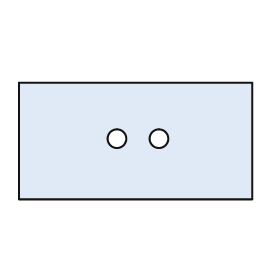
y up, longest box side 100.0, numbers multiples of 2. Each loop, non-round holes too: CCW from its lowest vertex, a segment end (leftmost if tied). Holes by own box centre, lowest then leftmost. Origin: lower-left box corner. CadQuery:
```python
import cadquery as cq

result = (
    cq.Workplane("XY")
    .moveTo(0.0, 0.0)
    .lineTo(100.0, 0.0)
    .lineTo(100.0, 50.0)
    .lineTo(0.0, 50.0)
    .close()
    .moveTo(42.0, 26.0)
    .circle(4.0)
    .moveTo(60.0, 26.0)
    .circle(4.0)
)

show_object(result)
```